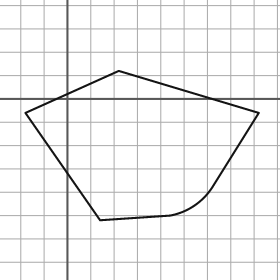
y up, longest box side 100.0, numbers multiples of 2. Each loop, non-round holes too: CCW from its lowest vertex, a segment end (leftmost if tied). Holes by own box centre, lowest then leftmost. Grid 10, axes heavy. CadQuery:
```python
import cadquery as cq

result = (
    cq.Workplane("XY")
    .moveTo(14.0, -52.0)
    .lineTo(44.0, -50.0)
    .threePointArc((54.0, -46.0), (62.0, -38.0))
    .lineTo(82.0, -6.0)
    .lineTo(22.0, 12.0)
    .lineTo(-18.0, -6.0)
    .close()
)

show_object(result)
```